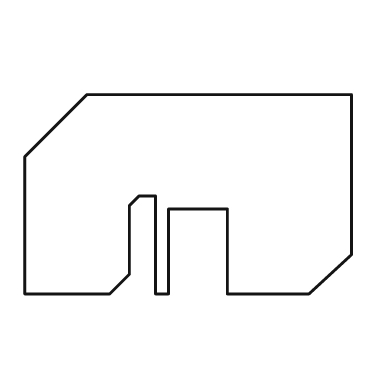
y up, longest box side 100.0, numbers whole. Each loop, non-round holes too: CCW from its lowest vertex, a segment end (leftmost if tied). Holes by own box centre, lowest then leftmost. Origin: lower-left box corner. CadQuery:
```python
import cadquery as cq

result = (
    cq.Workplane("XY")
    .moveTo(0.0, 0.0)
    .lineTo(26.0, 0.0)
    .lineTo(32.0, 6.0)
    .lineTo(32.0, 27.0)
    .lineTo(35.0, 30.0)
    .lineTo(40.0, 30.0)
    .lineTo(40.0, 0.0)
    .lineTo(44.0, 0.0)
    .lineTo(44.0, 26.0)
    .lineTo(62.0, 26.0)
    .lineTo(62.0, 0.0)
    .lineTo(87.0, 0.0)
    .lineTo(100.0, 12.0)
    .lineTo(100.0, 61.0)
    .lineTo(19.0, 61.0)
    .lineTo(0.0, 42.0)
    .close()
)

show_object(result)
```